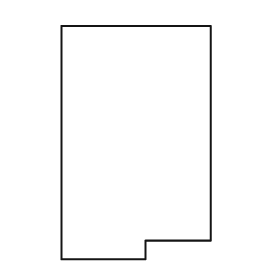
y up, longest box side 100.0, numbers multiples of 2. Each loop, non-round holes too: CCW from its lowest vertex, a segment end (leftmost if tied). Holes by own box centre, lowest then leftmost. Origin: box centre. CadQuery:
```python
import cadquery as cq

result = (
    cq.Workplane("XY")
    .moveTo(-32.0, -50.0)
    .lineTo(4.0, -50.0)
    .lineTo(4.0, -42.0)
    .lineTo(32.0, -42.0)
    .lineTo(32.0, 50.0)
    .lineTo(-32.0, 50.0)
    .close()
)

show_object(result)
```